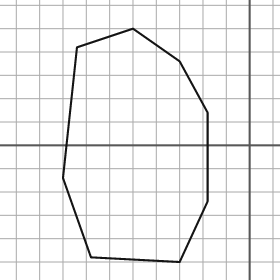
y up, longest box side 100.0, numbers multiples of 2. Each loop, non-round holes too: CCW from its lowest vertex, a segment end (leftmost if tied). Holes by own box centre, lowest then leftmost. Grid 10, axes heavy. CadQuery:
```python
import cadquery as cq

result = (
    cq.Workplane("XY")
    .moveTo(-30.0, -50.0)
    .lineTo(-18.0, -24.0)
    .lineTo(-18.0, 14.0)
    .lineTo(-30.0, 36.0)
    .lineTo(-50.0, 50.0)
    .lineTo(-74.0, 42.0)
    .lineTo(-80.0, -14.0)
    .lineTo(-68.0, -48.0)
    .close()
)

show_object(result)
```